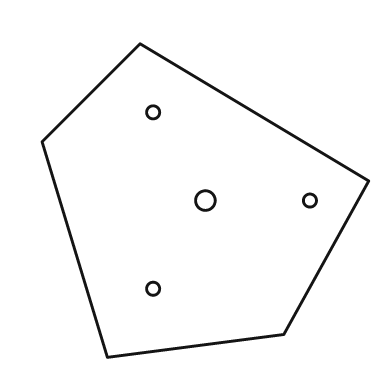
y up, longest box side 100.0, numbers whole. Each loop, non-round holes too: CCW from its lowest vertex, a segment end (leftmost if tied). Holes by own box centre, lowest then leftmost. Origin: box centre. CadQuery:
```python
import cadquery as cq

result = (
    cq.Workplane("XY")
    .moveTo(-30.0, -48.0)
    .lineTo(24.0, -41.0)
    .lineTo(50.0, 6.0)
    .lineTo(-20.0, 48.0)
    .lineTo(-50.0, 18.0)
    .close()
    .moveTo(-16.0, -27.0)
    .circle(2.0)
    .moveTo(0.0, 0.0)
    .circle(3.0)
    .moveTo(32.0, 0.0)
    .circle(2.0)
    .moveTo(-16.0, 27.0)
    .circle(2.0)
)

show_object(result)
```